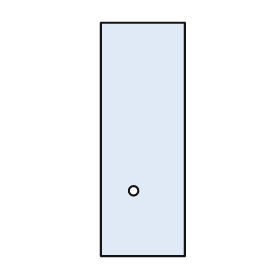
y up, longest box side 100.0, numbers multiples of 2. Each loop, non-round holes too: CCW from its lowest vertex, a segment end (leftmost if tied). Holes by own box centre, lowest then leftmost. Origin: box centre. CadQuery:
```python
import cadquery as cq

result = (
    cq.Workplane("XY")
    .moveTo(-18.0, -50.0)
    .lineTo(18.0, -50.0)
    .lineTo(18.0, 50.0)
    .lineTo(-18.0, 50.0)
    .close()
    .moveTo(-4.0, -22.0)
    .circle(2.0)
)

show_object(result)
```